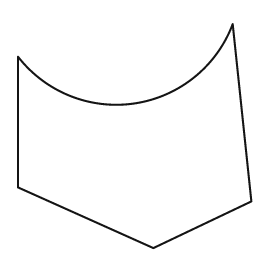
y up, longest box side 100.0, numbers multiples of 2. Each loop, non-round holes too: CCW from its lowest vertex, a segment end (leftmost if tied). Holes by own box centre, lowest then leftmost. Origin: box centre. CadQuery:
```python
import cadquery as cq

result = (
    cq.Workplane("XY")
    .moveTo(8.0, -48.0)
    .lineTo(50.0, -28.0)
    .lineTo(42.0, 48.0)
    .threePointArc((0.0, 14.0), (-50.0, 34.0))
    .lineTo(-50.0, -22.0)
    .close()
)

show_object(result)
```